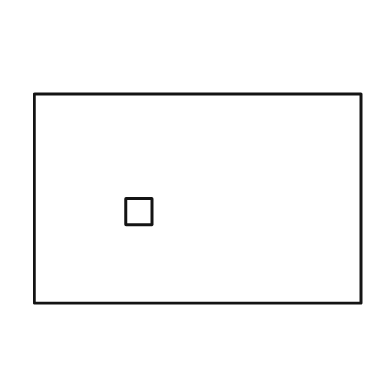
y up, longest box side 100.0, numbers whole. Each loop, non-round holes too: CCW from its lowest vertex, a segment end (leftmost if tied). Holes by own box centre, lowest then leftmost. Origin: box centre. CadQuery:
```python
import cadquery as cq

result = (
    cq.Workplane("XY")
    .moveTo(-50.0, -32.0)
    .lineTo(50.0, -32.0)
    .lineTo(50.0, 32.0)
    .lineTo(-50.0, 32.0)
    .close()
    .moveTo(-22.0, -8.0)
    .lineTo(-14.0, -8.0)
    .lineTo(-14.0, 0.0)
    .lineTo(-22.0, 0.0)
    .close()
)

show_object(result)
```